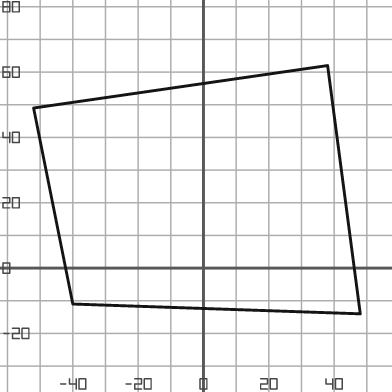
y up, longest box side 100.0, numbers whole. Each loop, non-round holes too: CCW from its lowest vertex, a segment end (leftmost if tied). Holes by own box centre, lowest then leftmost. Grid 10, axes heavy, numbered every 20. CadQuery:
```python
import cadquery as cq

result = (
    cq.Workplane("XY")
    .moveTo(48.0, -14.0)
    .lineTo(38.0, 62.0)
    .lineTo(-52.0, 49.0)
    .lineTo(-40.0, -11.0)
    .close()
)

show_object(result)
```